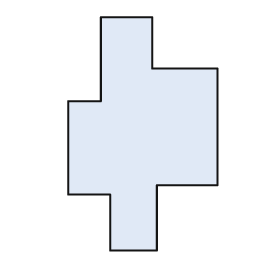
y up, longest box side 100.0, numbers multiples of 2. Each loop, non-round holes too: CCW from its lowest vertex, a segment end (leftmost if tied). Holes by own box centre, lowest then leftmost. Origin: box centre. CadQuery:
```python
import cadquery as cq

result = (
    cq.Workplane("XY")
    .moveTo(-14.0, -50.0)
    .lineTo(6.0, -50.0)
    .lineTo(6.0, -22.0)
    .lineTo(32.0, -22.0)
    .lineTo(32.0, 28.0)
    .lineTo(4.0, 28.0)
    .lineTo(4.0, 50.0)
    .lineTo(-18.0, 50.0)
    .lineTo(-18.0, 14.0)
    .lineTo(-32.0, 14.0)
    .lineTo(-32.0, -26.0)
    .lineTo(-14.0, -26.0)
    .close()
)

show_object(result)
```